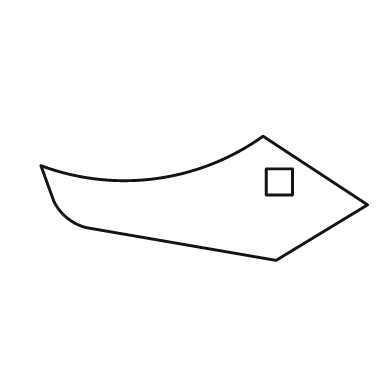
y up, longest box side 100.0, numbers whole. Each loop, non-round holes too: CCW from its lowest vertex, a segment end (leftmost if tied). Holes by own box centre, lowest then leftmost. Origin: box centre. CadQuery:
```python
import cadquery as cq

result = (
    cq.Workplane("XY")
    .moveTo(22.0, -19.0)
    .lineTo(50.0, -2.0)
    .lineTo(18.0, 19.0)
    .threePointArc((-15.0, 6.0), (-50.0, 10.0))
    .lineTo(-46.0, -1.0)
    .threePointArc((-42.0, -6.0), (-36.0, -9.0))
    .close()
    .moveTo(19.0, 1.0)
    .lineTo(27.0, 1.0)
    .lineTo(27.0, 9.0)
    .lineTo(19.0, 9.0)
    .close()
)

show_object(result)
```